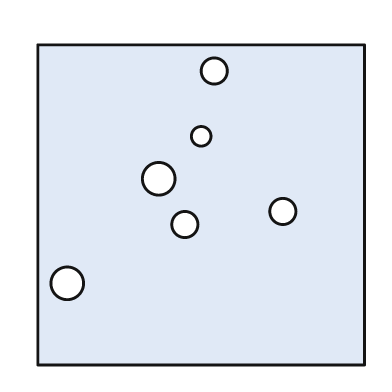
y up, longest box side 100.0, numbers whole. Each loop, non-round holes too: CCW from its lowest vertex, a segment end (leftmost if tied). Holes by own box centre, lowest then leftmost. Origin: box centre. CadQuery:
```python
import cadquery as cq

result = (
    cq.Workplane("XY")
    .moveTo(-50.0, -49.0)
    .lineTo(50.0, -49.0)
    .lineTo(50.0, 49.0)
    .lineTo(-50.0, 49.0)
    .close()
    .moveTo(-41.0, -24.0)
    .circle(5.0)
    .moveTo(-5.0, -6.0)
    .circle(4.0)
    .moveTo(25.0, -2.0)
    .circle(4.0)
    .moveTo(-13.0, 8.0)
    .circle(5.0)
    .moveTo(0.0, 21.0)
    .circle(3.0)
    .moveTo(4.0, 41.0)
    .circle(4.0)
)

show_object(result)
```